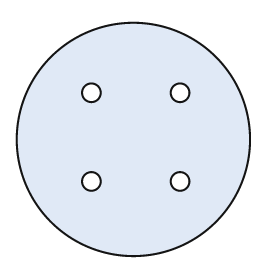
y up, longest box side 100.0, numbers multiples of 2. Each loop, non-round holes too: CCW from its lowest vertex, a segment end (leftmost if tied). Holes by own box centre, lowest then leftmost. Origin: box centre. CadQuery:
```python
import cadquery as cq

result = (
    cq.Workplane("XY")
    .moveTo(0.0, 0.0)
    .circle(50.0)
    .moveTo(-18.0, -18.0)
    .circle(4.0)
    .moveTo(20.0, -18.0)
    .circle(4.0)
    .moveTo(-18.0, 20.0)
    .circle(4.0)
    .moveTo(20.0, 20.0)
    .circle(4.0)
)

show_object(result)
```